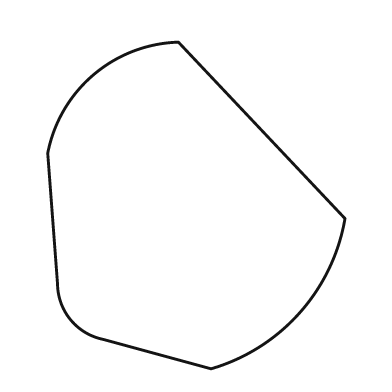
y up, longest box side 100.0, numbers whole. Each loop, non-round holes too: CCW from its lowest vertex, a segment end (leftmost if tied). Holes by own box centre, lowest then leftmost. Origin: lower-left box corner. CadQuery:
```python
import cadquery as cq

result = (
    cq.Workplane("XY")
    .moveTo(50.0, 0.0)
    .threePointArc((77.0, 17.0), (91.0, 46.0))
    .lineTo(40.0, 100.0)
    .threePointArc((14.0, 90.0), (0.0, 66.0))
    .lineTo(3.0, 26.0)
    .threePointArc((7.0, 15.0), (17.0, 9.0))
    .close()
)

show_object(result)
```